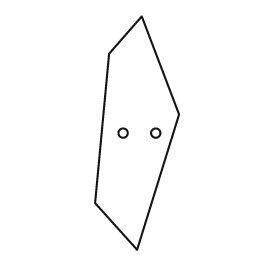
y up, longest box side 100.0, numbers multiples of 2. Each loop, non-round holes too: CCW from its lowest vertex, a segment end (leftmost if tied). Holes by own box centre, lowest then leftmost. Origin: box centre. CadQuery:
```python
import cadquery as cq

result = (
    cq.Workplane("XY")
    .moveTo(0.0, -50.0)
    .lineTo(18.0, 8.0)
    .lineTo(2.0, 50.0)
    .lineTo(-12.0, 34.0)
    .lineTo(-18.0, -30.0)
    .close()
    .moveTo(-6.0, 0.0)
    .circle(2.0)
    .moveTo(8.0, 0.0)
    .circle(2.0)
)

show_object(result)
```